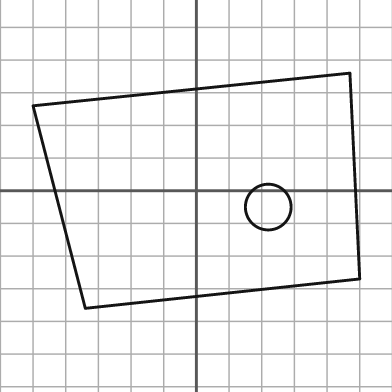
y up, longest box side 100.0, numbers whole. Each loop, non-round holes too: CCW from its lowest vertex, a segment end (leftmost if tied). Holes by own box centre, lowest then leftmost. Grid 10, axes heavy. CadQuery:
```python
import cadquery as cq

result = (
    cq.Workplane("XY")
    .moveTo(-34.0, -36.0)
    .lineTo(50.0, -27.0)
    .lineTo(47.0, 36.0)
    .lineTo(-50.0, 26.0)
    .close()
    .moveTo(22.0, -5.0)
    .circle(7.0)
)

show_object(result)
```